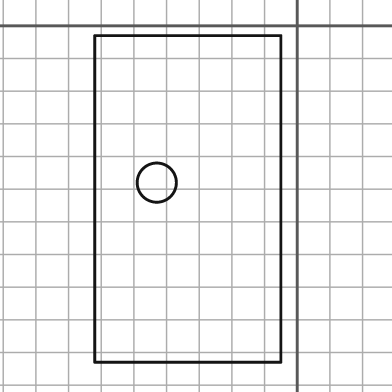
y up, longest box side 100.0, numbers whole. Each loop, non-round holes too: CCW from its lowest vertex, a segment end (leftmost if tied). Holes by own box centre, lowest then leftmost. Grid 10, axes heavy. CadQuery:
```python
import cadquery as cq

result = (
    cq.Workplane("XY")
    .moveTo(-62.0, -103.0)
    .lineTo(-5.0, -103.0)
    .lineTo(-5.0, -3.0)
    .lineTo(-62.0, -3.0)
    .close()
    .moveTo(-43.0, -48.0)
    .circle(6.0)
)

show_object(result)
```